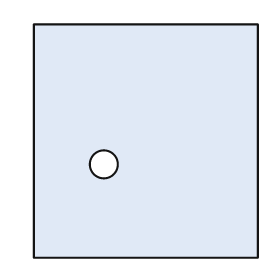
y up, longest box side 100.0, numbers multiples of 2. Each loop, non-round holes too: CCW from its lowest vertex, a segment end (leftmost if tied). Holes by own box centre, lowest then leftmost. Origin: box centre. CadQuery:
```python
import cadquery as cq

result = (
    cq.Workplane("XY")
    .moveTo(-48.0, -50.0)
    .lineTo(48.0, -50.0)
    .lineTo(48.0, 50.0)
    .lineTo(-48.0, 50.0)
    .close()
    .moveTo(-18.0, -10.0)
    .circle(6.0)
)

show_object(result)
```